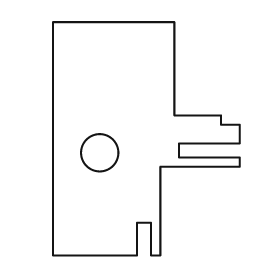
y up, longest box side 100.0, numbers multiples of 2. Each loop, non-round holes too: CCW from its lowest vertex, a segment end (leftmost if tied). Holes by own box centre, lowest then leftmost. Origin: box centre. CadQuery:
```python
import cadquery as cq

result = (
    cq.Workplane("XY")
    .moveTo(-40.0, -50.0)
    .lineTo(-4.0, -50.0)
    .lineTo(-4.0, -36.0)
    .lineTo(2.0, -36.0)
    .lineTo(2.0, -50.0)
    .lineTo(6.0, -50.0)
    .lineTo(6.0, -12.0)
    .lineTo(40.0, -12.0)
    .lineTo(40.0, -8.0)
    .lineTo(14.0, -8.0)
    .lineTo(14.0, -2.0)
    .lineTo(40.0, -2.0)
    .lineTo(40.0, 6.0)
    .lineTo(32.0, 6.0)
    .lineTo(32.0, 10.0)
    .lineTo(12.0, 10.0)
    .lineTo(12.0, 50.0)
    .lineTo(-40.0, 50.0)
    .close()
    .moveTo(-20.0, -6.0)
    .circle(8.0)
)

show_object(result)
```